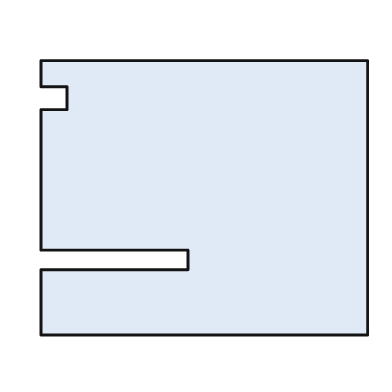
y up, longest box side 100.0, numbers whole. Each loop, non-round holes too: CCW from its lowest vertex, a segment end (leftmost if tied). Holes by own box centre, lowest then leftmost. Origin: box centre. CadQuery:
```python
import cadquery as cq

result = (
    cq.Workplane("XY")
    .moveTo(-50.0, -42.0)
    .lineTo(50.0, -42.0)
    .lineTo(50.0, 42.0)
    .lineTo(-50.0, 42.0)
    .lineTo(-50.0, 34.0)
    .lineTo(-42.0, 34.0)
    .lineTo(-42.0, 27.0)
    .lineTo(-50.0, 27.0)
    .lineTo(-50.0, -16.0)
    .lineTo(-5.0, -16.0)
    .lineTo(-5.0, -22.0)
    .lineTo(-50.0, -22.0)
    .close()
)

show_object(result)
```